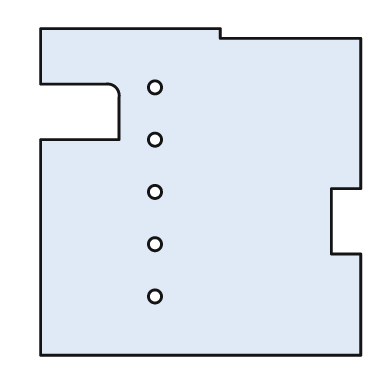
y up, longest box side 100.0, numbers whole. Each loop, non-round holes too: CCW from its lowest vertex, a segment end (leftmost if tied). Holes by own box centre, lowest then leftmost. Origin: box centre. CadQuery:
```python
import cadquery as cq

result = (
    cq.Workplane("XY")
    .moveTo(-49.0, -50.0)
    .lineTo(49.0, -50.0)
    .lineTo(49.0, -19.0)
    .lineTo(40.0, -19.0)
    .lineTo(40.0, 1.0)
    .lineTo(49.0, 1.0)
    .lineTo(49.0, 47.0)
    .lineTo(6.0, 47.0)
    .lineTo(6.0, 50.0)
    .lineTo(-49.0, 50.0)
    .lineTo(-49.0, 33.0)
    .lineTo(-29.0, 33.0)
    .threePointArc((-26.0, 32.0), (-25.0, 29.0))
    .lineTo(-25.0, 16.0)
    .lineTo(-49.0, 16.0)
    .close()
    .moveTo(-14.0, -32.0)
    .circle(2.0)
    .moveTo(-14.0, -16.0)
    .circle(2.0)
    .moveTo(-14.0, 0.0)
    .circle(2.0)
    .moveTo(-14.0, 16.0)
    .circle(2.0)
    .moveTo(-14.0, 32.0)
    .circle(2.0)
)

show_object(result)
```